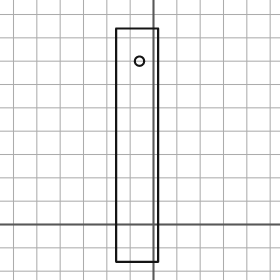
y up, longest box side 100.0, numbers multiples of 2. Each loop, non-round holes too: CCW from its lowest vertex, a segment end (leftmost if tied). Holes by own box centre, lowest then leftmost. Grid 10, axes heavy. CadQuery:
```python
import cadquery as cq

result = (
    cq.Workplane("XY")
    .moveTo(-16.0, -16.0)
    .lineTo(2.0, -16.0)
    .lineTo(2.0, 84.0)
    .lineTo(-16.0, 84.0)
    .close()
    .moveTo(-6.0, 70.0)
    .circle(2.0)
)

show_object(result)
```